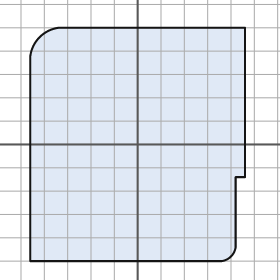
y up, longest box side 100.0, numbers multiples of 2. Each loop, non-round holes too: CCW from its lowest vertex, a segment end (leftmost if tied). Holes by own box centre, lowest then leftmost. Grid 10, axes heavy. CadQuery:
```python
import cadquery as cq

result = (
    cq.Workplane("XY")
    .moveTo(-46.0, -50.0)
    .lineTo(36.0, -50.0)
    .threePointArc((40.0, -48.0), (42.0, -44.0))
    .lineTo(42.0, -14.0)
    .lineTo(46.0, -14.0)
    .lineTo(46.0, 50.0)
    .lineTo(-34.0, 50.0)
    .threePointArc((-42.0, 46.0), (-46.0, 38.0))
    .close()
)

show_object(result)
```